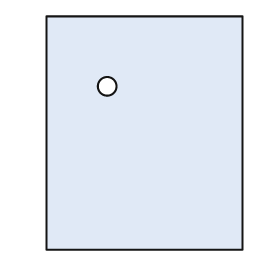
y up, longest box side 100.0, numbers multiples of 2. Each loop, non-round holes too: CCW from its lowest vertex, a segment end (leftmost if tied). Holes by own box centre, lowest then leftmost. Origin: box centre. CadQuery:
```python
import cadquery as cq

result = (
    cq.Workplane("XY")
    .moveTo(-42.0, -50.0)
    .lineTo(42.0, -50.0)
    .lineTo(42.0, 50.0)
    .lineTo(-42.0, 50.0)
    .close()
    .moveTo(-16.0, 20.0)
    .circle(4.0)
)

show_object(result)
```